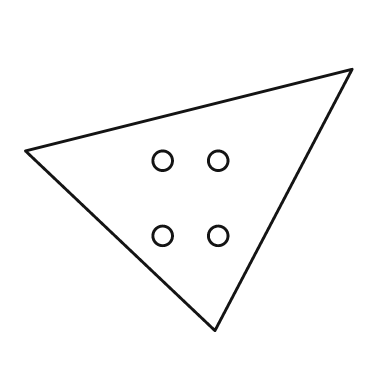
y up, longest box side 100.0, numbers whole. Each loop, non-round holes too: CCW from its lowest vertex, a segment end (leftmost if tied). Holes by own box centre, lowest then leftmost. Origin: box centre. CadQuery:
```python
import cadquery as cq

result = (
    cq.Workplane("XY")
    .moveTo(8.0, -40.0)
    .lineTo(50.0, 40.0)
    .lineTo(-50.0, 15.0)
    .close()
    .moveTo(-8.0, -11.0)
    .circle(3.0)
    .moveTo(9.0, -11.0)
    .circle(3.0)
    .moveTo(-8.0, 12.0)
    .circle(3.0)
    .moveTo(9.0, 12.0)
    .circle(3.0)
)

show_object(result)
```